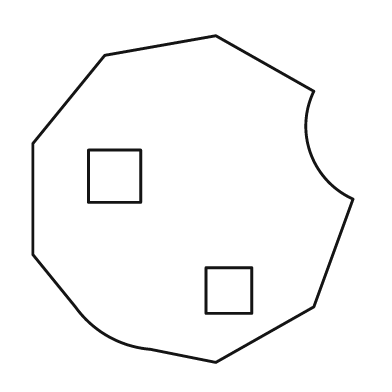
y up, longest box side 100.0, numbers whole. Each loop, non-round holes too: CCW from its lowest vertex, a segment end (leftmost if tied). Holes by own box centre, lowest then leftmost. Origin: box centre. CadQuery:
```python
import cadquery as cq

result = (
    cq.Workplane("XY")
    .moveTo(7.0, -50.0)
    .lineTo(37.0, -33.0)
    .lineTo(49.0, 0.0)
    .threePointArc((36.0, 14.0), (37.0, 33.0))
    .lineTo(7.0, 50.0)
    .lineTo(-27.0, 44.0)
    .lineTo(-49.0, 17.0)
    .lineTo(-49.0, -17.0)
    .lineTo(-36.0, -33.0)
    .threePointArc((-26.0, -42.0), (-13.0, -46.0))
    .close()
    .moveTo(4.0, -35.0)
    .lineTo(18.0, -35.0)
    .lineTo(18.0, -21.0)
    .lineTo(4.0, -21.0)
    .close()
    .moveTo(-32.0, -1.0)
    .lineTo(-16.0, -1.0)
    .lineTo(-16.0, 15.0)
    .lineTo(-32.0, 15.0)
    .close()
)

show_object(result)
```